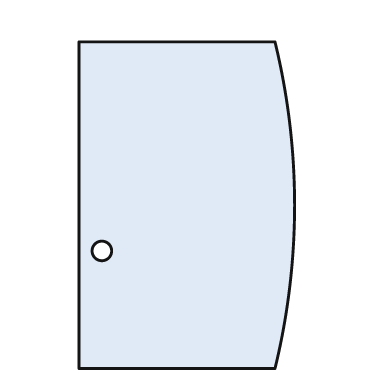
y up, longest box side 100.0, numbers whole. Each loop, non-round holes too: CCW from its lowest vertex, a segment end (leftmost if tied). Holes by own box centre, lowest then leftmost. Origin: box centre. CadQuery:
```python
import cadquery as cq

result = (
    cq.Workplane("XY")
    .moveTo(-33.0, -50.0)
    .lineTo(27.0, -50.0)
    .threePointArc((33.0, 0.0), (27.0, 50.0))
    .lineTo(-33.0, 50.0)
    .close()
    .moveTo(-26.0, -14.0)
    .circle(3.0)
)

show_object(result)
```